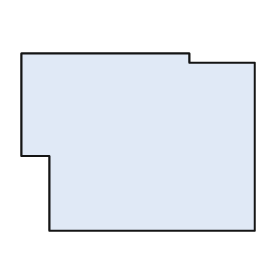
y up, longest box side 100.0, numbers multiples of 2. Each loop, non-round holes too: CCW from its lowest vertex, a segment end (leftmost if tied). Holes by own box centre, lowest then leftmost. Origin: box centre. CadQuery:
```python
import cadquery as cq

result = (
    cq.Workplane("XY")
    .moveTo(-38.0, -38.0)
    .lineTo(50.0, -38.0)
    .lineTo(50.0, 34.0)
    .lineTo(22.0, 34.0)
    .lineTo(22.0, 38.0)
    .lineTo(-50.0, 38.0)
    .lineTo(-50.0, -6.0)
    .lineTo(-38.0, -6.0)
    .close()
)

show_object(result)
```